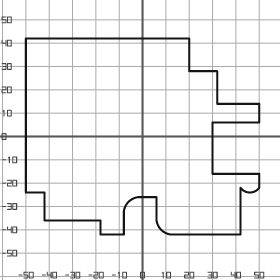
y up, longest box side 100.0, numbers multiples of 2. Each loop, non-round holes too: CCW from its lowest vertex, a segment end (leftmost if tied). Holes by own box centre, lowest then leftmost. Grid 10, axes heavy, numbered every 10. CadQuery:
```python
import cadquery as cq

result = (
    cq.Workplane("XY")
    .moveTo(-18.0, -42.0)
    .lineTo(-8.0, -42.0)
    .lineTo(-8.0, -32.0)
    .threePointArc((-6.0, -28.0), (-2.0, -26.0))
    .lineTo(6.0, -26.0)
    .lineTo(6.0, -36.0)
    .threePointArc((8.0, -40.0), (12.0, -42.0))
    .lineTo(42.0, -42.0)
    .lineTo(42.0, -22.0)
    .threePointArc((46.0, -24.0), (50.0, -22.0))
    .lineTo(50.0, -16.0)
    .lineTo(30.0, -16.0)
    .lineTo(30.0, 6.0)
    .lineTo(50.0, 6.0)
    .lineTo(50.0, 14.0)
    .lineTo(32.0, 14.0)
    .lineTo(32.0, 28.0)
    .lineTo(20.0, 28.0)
    .lineTo(20.0, 42.0)
    .lineTo(-50.0, 42.0)
    .lineTo(-50.0, -24.0)
    .lineTo(-42.0, -24.0)
    .lineTo(-42.0, -36.0)
    .lineTo(-18.0, -36.0)
    .close()
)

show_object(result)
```